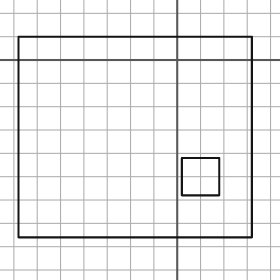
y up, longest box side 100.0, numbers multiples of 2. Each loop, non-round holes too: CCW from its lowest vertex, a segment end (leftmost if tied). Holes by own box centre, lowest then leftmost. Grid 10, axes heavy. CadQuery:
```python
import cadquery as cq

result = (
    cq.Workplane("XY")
    .moveTo(-68.0, -76.0)
    .lineTo(32.0, -76.0)
    .lineTo(32.0, 10.0)
    .lineTo(-68.0, 10.0)
    .close()
    .moveTo(2.0, -58.0)
    .lineTo(18.0, -58.0)
    .lineTo(18.0, -42.0)
    .lineTo(2.0, -42.0)
    .close()
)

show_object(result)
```